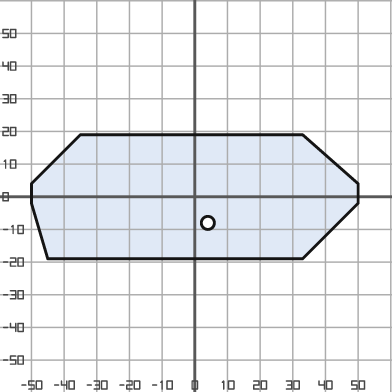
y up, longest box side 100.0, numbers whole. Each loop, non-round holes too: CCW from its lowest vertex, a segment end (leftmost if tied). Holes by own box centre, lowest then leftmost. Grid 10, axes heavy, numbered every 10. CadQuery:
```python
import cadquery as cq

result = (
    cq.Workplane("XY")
    .moveTo(-45.0, -19.0)
    .lineTo(33.0, -19.0)
    .lineTo(50.0, -2.0)
    .lineTo(50.0, 4.0)
    .lineTo(33.0, 19.0)
    .lineTo(-35.0, 19.0)
    .lineTo(-50.0, 4.0)
    .lineTo(-50.0, -2.0)
    .close()
    .moveTo(4.0, -8.0)
    .circle(2.0)
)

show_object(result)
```